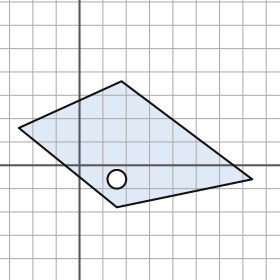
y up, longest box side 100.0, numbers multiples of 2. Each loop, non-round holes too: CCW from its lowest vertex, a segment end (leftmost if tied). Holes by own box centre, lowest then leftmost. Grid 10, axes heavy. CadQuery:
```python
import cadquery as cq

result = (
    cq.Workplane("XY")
    .moveTo(16.0, -18.0)
    .lineTo(74.0, -6.0)
    .lineTo(18.0, 36.0)
    .lineTo(-26.0, 16.0)
    .close()
    .moveTo(16.0, -6.0)
    .circle(4.0)
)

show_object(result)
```